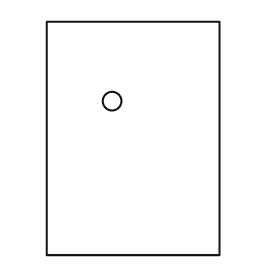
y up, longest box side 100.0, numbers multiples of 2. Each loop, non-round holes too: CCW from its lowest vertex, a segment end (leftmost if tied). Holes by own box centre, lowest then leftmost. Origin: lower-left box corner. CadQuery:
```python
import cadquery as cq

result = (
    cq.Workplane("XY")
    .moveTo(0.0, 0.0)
    .lineTo(74.0, 0.0)
    .lineTo(74.0, 100.0)
    .lineTo(0.0, 100.0)
    .close()
    .moveTo(28.0, 66.0)
    .circle(4.0)
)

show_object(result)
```